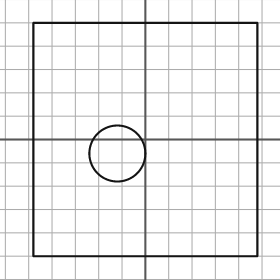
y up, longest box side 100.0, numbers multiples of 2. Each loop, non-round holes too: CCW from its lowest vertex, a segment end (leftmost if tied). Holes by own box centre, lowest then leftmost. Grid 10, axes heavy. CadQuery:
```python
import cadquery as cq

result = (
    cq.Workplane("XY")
    .moveTo(-48.0, -50.0)
    .lineTo(48.0, -50.0)
    .lineTo(48.0, 50.0)
    .lineTo(-48.0, 50.0)
    .close()
    .moveTo(-12.0, -6.0)
    .circle(12.0)
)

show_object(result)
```